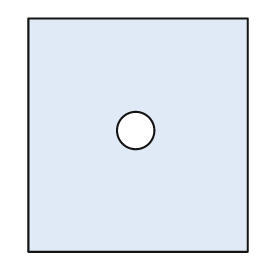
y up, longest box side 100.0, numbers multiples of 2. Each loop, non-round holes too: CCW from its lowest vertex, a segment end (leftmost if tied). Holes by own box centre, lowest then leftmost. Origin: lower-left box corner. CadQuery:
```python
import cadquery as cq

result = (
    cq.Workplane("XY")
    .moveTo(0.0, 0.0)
    .lineTo(94.0, 0.0)
    .lineTo(94.0, 100.0)
    .lineTo(0.0, 100.0)
    .close()
    .moveTo(46.0, 52.0)
    .circle(8.0)
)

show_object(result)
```